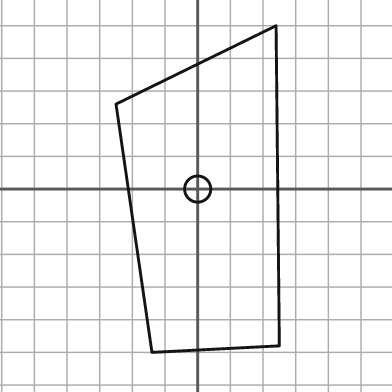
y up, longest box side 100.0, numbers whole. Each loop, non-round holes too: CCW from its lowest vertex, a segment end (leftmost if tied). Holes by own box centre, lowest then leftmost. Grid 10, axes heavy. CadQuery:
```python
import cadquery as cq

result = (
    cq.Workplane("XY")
    .moveTo(-14.0, -50.0)
    .lineTo(25.0, -48.0)
    .lineTo(24.0, 50.0)
    .lineTo(-25.0, 26.0)
    .close()
    .moveTo(0.0, 0.0)
    .circle(4.0)
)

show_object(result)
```